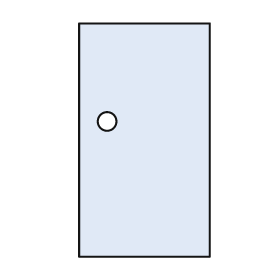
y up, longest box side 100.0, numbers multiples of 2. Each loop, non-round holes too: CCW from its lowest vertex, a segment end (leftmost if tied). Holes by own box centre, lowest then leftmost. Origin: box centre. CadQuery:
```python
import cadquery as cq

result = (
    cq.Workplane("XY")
    .moveTo(-28.0, -50.0)
    .lineTo(28.0, -50.0)
    .lineTo(28.0, 50.0)
    .lineTo(-28.0, 50.0)
    .close()
    .moveTo(-16.0, 8.0)
    .circle(4.0)
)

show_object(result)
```